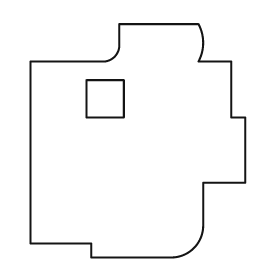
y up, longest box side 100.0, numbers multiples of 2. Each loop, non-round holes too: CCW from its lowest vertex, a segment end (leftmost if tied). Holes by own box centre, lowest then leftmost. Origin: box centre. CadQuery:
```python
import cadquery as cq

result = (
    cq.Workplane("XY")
    .moveTo(-20.0, -50.0)
    .lineTo(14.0, -50.0)
    .threePointArc((24.0, -46.0), (28.0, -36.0))
    .lineTo(28.0, -18.0)
    .lineTo(46.0, -18.0)
    .lineTo(46.0, 10.0)
    .lineTo(40.0, 10.0)
    .lineTo(40.0, 34.0)
    .lineTo(26.0, 34.0)
    .threePointArc((28.0, 42.0), (26.0, 50.0))
    .lineTo(-8.0, 50.0)
    .lineTo(-8.0, 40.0)
    .threePointArc((-10.0, 36.0), (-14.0, 34.0))
    .lineTo(-46.0, 34.0)
    .lineTo(-46.0, -44.0)
    .lineTo(-20.0, -44.0)
    .close()
    .moveTo(-22.0, 10.0)
    .lineTo(-6.0, 10.0)
    .lineTo(-6.0, 26.0)
    .lineTo(-22.0, 26.0)
    .close()
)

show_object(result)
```